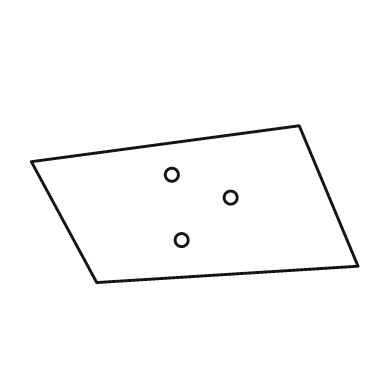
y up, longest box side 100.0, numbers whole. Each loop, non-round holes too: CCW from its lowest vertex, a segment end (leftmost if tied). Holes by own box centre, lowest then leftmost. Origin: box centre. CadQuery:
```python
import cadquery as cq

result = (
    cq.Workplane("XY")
    .moveTo(-30.0, -24.0)
    .lineTo(50.0, -19.0)
    .lineTo(32.0, 24.0)
    .lineTo(-50.0, 13.0)
    .close()
    .moveTo(-4.0, -11.0)
    .circle(2.0)
    .moveTo(11.0, 2.0)
    .circle(2.0)
    .moveTo(-7.0, 9.0)
    .circle(2.0)
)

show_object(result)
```